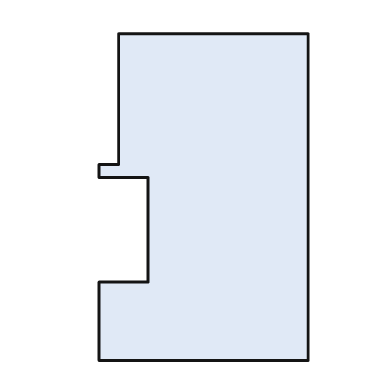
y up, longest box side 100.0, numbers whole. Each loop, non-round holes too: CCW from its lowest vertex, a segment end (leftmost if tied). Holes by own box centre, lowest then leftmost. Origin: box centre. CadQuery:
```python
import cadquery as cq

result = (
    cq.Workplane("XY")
    .moveTo(-32.0, -50.0)
    .lineTo(32.0, -50.0)
    .lineTo(32.0, 50.0)
    .lineTo(-26.0, 50.0)
    .lineTo(-26.0, 10.0)
    .lineTo(-32.0, 10.0)
    .lineTo(-32.0, 6.0)
    .lineTo(-17.0, 6.0)
    .lineTo(-17.0, -26.0)
    .lineTo(-32.0, -26.0)
    .close()
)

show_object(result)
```